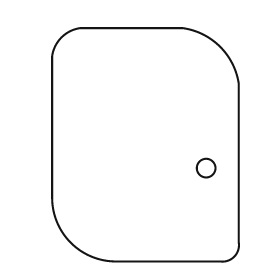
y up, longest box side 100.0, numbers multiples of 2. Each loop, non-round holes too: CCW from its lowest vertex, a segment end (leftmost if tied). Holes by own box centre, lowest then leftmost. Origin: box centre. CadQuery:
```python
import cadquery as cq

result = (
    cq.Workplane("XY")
    .moveTo(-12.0, -50.0)
    .lineTo(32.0, -50.0)
    .threePointArc((38.0, -48.0), (40.0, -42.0))
    .lineTo(40.0, 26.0)
    .threePointArc((32.0, 42.0), (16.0, 50.0))
    .lineTo(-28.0, 50.0)
    .threePointArc((-36.0, 46.0), (-40.0, 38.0))
    .lineTo(-40.0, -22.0)
    .threePointArc((-32.0, -42.0), (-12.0, -50.0))
    .close()
    .moveTo(26.0, -10.0)
    .circle(4.0)
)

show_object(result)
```